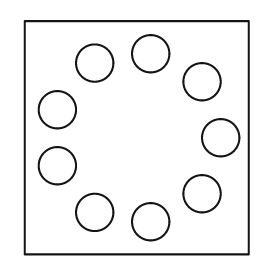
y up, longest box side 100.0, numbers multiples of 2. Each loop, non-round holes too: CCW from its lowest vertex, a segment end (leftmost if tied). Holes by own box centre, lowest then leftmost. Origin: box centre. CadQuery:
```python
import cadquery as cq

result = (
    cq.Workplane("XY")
    .moveTo(-48.0, -50.0)
    .lineTo(48.0, -50.0)
    .lineTo(48.0, 50.0)
    .lineTo(-48.0, 50.0)
    .close()
    .moveTo(6.0, -36.0)
    .circle(8.0)
    .moveTo(-18.0, -32.0)
    .circle(8.0)
    .moveTo(28.0, -24.0)
    .circle(8.0)
    .moveTo(-34.0, -12.0)
    .circle(8.0)
    .moveTo(36.0, 0.0)
    .circle(8.0)
    .moveTo(-34.0, 12.0)
    .circle(8.0)
    .moveTo(28.0, 24.0)
    .circle(8.0)
    .moveTo(-18.0, 32.0)
    .circle(8.0)
    .moveTo(6.0, 36.0)
    .circle(8.0)
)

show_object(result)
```